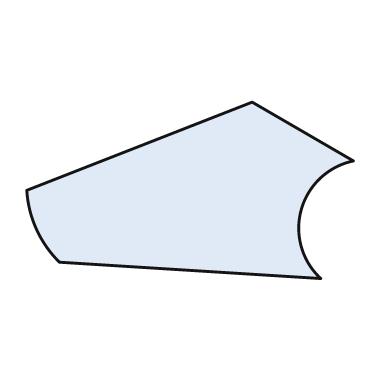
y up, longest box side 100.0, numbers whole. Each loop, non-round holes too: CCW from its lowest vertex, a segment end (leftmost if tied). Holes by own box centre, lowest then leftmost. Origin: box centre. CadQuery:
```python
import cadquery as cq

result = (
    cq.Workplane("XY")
    .moveTo(40.0, -27.0)
    .threePointArc((34.0, -6.0), (50.0, 9.0))
    .lineTo(19.0, 27.0)
    .lineTo(-50.0, 0.0)
    .threePointArc((-47.0, -12.0), (-40.0, -22.0))
    .close()
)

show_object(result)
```